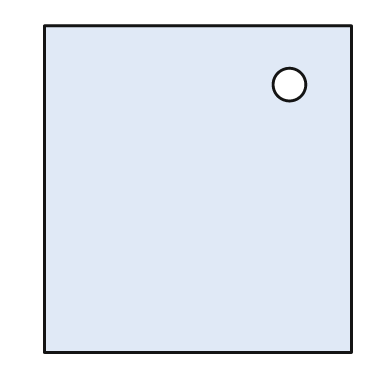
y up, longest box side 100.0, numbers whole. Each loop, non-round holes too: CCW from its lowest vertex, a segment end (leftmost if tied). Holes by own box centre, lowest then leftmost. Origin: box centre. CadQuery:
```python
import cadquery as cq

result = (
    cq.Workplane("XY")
    .moveTo(-47.0, -50.0)
    .lineTo(47.0, -50.0)
    .lineTo(47.0, 50.0)
    .lineTo(-47.0, 50.0)
    .close()
    .moveTo(28.0, 32.0)
    .circle(5.0)
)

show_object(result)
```